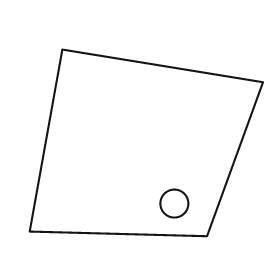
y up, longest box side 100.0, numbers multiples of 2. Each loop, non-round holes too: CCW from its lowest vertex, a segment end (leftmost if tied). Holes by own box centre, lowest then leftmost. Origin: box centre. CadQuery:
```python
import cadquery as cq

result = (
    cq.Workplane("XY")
    .moveTo(26.0, -40.0)
    .lineTo(50.0, 26.0)
    .lineTo(-36.0, 40.0)
    .lineTo(-50.0, -38.0)
    .close()
    .moveTo(12.0, -26.0)
    .circle(6.0)
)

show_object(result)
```